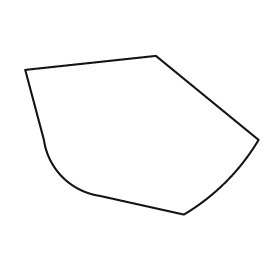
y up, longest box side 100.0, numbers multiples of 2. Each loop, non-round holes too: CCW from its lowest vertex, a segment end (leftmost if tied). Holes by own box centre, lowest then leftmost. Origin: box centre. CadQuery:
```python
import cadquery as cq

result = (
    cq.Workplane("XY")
    .moveTo(18.0, -34.0)
    .threePointArc((36.0, -20.0), (50.0, -2.0))
    .lineTo(6.0, 34.0)
    .lineTo(-50.0, 28.0)
    .lineTo(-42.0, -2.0)
    .threePointArc((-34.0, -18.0), (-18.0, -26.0))
    .close()
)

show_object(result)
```